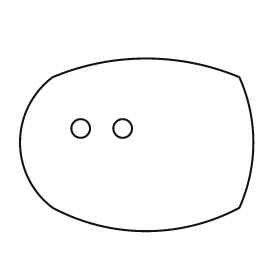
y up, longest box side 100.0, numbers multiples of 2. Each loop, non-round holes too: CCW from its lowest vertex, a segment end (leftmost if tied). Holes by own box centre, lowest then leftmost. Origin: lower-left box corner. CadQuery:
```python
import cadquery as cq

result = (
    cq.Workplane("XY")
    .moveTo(14.0, 10.0)
    .threePointArc((54.0, 0.0), (94.0, 10.0))
    .threePointArc((100.0, 38.0), (94.0, 66.0))
    .threePointArc((54.0, 74.0), (14.0, 66.0))
    .threePointArc((0.0, 38.0), (14.0, 10.0))
    .close()
    .moveTo(26.0, 44.0)
    .circle(4.0)
    .moveTo(44.0, 44.0)
    .circle(4.0)
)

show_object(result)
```